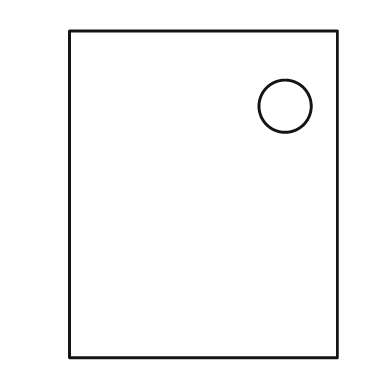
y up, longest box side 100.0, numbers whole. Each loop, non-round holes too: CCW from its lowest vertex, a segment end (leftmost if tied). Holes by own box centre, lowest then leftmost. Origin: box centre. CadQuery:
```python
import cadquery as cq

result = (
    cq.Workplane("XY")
    .moveTo(-41.0, -50.0)
    .lineTo(41.0, -50.0)
    .lineTo(41.0, 50.0)
    .lineTo(-41.0, 50.0)
    .close()
    .moveTo(25.0, 27.0)
    .circle(8.0)
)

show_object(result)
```